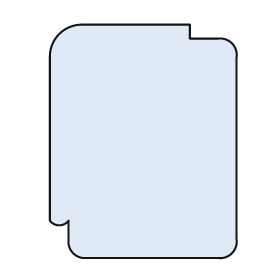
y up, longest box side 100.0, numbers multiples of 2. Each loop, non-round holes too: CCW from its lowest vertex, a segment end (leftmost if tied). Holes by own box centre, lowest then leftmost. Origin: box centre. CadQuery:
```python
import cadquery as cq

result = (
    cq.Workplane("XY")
    .moveTo(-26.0, -50.0)
    .lineTo(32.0, -50.0)
    .threePointArc((38.0, -48.0), (40.0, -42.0))
    .lineTo(40.0, 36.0)
    .threePointArc((38.0, 42.0), (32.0, 44.0))
    .lineTo(20.0, 44.0)
    .lineTo(20.0, 50.0)
    .lineTo(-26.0, 50.0)
    .threePointArc((-36.0, 46.0), (-40.0, 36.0))
    .lineTo(-40.0, -34.0)
    .threePointArc((-36.0, -36.0), (-32.0, -34.0))
    .lineTo(-32.0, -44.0)
    .threePointArc((-30.0, -48.0), (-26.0, -50.0))
    .close()
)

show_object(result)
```